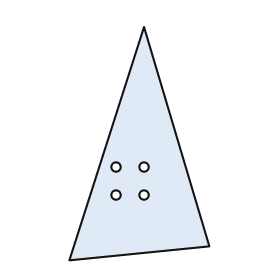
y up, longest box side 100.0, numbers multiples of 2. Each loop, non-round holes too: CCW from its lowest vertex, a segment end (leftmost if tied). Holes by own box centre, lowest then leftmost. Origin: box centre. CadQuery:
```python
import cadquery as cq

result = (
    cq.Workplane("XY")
    .moveTo(-30.0, -50.0)
    .lineTo(30.0, -44.0)
    .lineTo(2.0, 50.0)
    .close()
    .moveTo(-10.0, -22.0)
    .circle(2.0)
    .moveTo(2.0, -22.0)
    .circle(2.0)
    .moveTo(-10.0, -10.0)
    .circle(2.0)
    .moveTo(2.0, -10.0)
    .circle(2.0)
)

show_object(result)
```